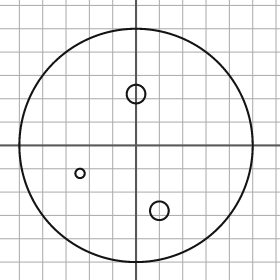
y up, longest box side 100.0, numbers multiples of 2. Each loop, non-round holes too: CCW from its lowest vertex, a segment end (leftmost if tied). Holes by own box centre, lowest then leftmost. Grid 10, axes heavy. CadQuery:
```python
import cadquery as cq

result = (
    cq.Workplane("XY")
    .moveTo(0.0, 0.0)
    .circle(50.0)
    .moveTo(10.0, -28.0)
    .circle(4.0)
    .moveTo(-24.0, -12.0)
    .circle(2.0)
    .moveTo(0.0, 22.0)
    .circle(4.0)
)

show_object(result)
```